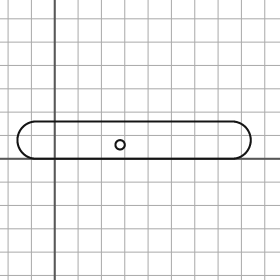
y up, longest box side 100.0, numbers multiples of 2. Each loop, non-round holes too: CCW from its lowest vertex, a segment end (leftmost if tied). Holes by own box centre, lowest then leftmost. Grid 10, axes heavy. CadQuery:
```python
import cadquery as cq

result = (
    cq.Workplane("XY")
    .moveTo(-8.0, 0.0)
    .lineTo(76.0, 0.0)
    .threePointArc((84.0, 8.0), (76.0, 16.0))
    .lineTo(-8.0, 16.0)
    .threePointArc((-16.0, 8.0), (-8.0, 0.0))
    .close()
    .moveTo(28.0, 6.0)
    .circle(2.0)
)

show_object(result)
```